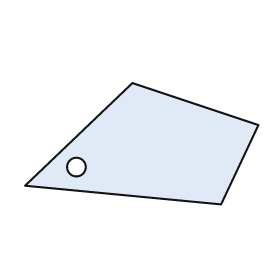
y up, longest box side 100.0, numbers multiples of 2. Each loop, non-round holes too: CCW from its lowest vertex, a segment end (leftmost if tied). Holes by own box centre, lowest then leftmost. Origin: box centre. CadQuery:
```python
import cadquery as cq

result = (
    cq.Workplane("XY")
    .moveTo(34.0, -26.0)
    .lineTo(50.0, 8.0)
    .lineTo(-4.0, 26.0)
    .lineTo(-50.0, -18.0)
    .close()
    .moveTo(-28.0, -10.0)
    .circle(4.0)
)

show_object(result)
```